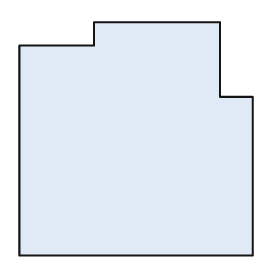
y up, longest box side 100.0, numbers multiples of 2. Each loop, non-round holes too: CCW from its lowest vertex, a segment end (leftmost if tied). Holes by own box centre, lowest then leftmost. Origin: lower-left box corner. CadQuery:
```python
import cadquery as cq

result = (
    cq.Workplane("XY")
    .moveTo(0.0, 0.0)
    .lineTo(100.0, 0.0)
    .lineTo(100.0, 68.0)
    .lineTo(86.0, 68.0)
    .lineTo(86.0, 100.0)
    .lineTo(32.0, 100.0)
    .lineTo(32.0, 90.0)
    .lineTo(0.0, 90.0)
    .close()
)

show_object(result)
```